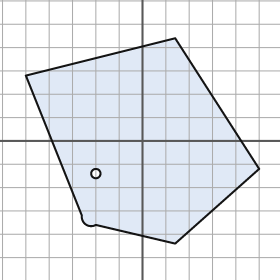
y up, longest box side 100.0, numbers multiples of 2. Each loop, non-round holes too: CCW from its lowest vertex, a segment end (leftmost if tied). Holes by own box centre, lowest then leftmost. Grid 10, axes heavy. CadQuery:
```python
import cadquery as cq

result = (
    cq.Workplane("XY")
    .moveTo(14.0, -44.0)
    .lineTo(50.0, -12.0)
    .lineTo(14.0, 44.0)
    .lineTo(-50.0, 28.0)
    .lineTo(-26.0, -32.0)
    .threePointArc((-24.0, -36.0), (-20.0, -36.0))
    .close()
    .moveTo(-20.0, -14.0)
    .circle(2.0)
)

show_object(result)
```